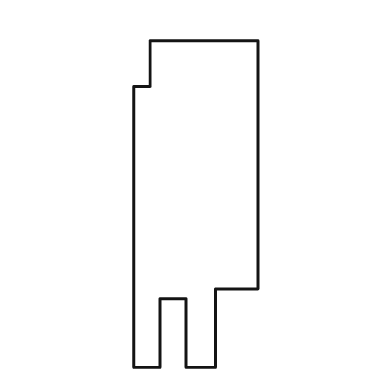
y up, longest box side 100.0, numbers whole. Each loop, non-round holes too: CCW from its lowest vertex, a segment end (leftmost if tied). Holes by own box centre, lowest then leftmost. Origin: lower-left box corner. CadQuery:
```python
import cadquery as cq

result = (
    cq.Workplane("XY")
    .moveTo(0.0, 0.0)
    .lineTo(8.0, 0.0)
    .lineTo(8.0, 21.0)
    .lineTo(16.0, 21.0)
    .lineTo(16.0, 0.0)
    .lineTo(25.0, 0.0)
    .lineTo(25.0, 24.0)
    .lineTo(38.0, 24.0)
    .lineTo(38.0, 100.0)
    .lineTo(5.0, 100.0)
    .lineTo(5.0, 86.0)
    .lineTo(0.0, 86.0)
    .close()
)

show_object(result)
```